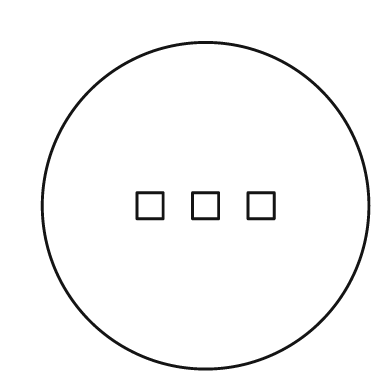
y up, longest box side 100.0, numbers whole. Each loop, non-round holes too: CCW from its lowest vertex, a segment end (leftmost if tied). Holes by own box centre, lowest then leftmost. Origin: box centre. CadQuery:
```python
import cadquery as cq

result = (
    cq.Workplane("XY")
    .moveTo(0.0, 0.0)
    .circle(50.0)
    .moveTo(-21.0, -4.0)
    .lineTo(-13.0, -4.0)
    .lineTo(-13.0, 4.0)
    .lineTo(-21.0, 4.0)
    .close()
    .moveTo(-4.0, -4.0)
    .lineTo(4.0, -4.0)
    .lineTo(4.0, 4.0)
    .lineTo(-4.0, 4.0)
    .close()
    .moveTo(13.0, -4.0)
    .lineTo(21.0, -4.0)
    .lineTo(21.0, 4.0)
    .lineTo(13.0, 4.0)
    .close()
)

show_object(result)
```